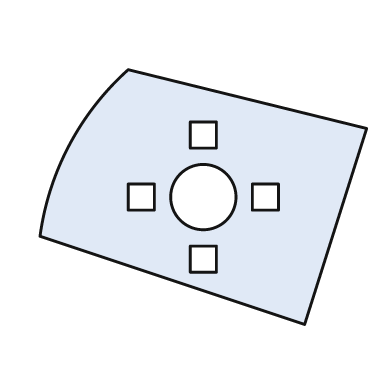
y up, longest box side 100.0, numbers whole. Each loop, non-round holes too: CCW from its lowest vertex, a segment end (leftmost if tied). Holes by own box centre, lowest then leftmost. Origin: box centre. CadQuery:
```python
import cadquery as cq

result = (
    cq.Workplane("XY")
    .moveTo(31.0, -39.0)
    .lineTo(50.0, 21.0)
    .lineTo(-23.0, 39.0)
    .threePointArc((-41.0, 16.0), (-50.0, -12.0))
    .close()
    .moveTo(-4.0, -23.0)
    .lineTo(4.0, -23.0)
    .lineTo(4.0, -15.0)
    .lineTo(-4.0, -15.0)
    .close()
    .moveTo(-23.0, -4.0)
    .lineTo(-15.0, -4.0)
    .lineTo(-15.0, 4.0)
    .lineTo(-23.0, 4.0)
    .close()
    .moveTo(0.0, 0.0)
    .circle(10.0)
    .moveTo(15.0, -4.0)
    .lineTo(23.0, -4.0)
    .lineTo(23.0, 4.0)
    .lineTo(15.0, 4.0)
    .close()
    .moveTo(-4.0, 15.0)
    .lineTo(4.0, 15.0)
    .lineTo(4.0, 23.0)
    .lineTo(-4.0, 23.0)
    .close()
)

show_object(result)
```